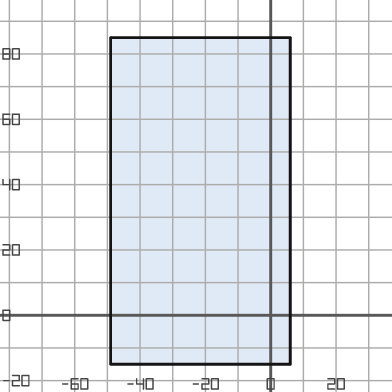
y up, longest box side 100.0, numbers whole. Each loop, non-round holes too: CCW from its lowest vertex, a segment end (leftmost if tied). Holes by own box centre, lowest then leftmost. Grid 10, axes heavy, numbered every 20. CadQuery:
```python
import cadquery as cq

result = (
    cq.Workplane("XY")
    .moveTo(-49.0, -15.0)
    .lineTo(6.0, -15.0)
    .lineTo(6.0, 85.0)
    .lineTo(-49.0, 85.0)
    .close()
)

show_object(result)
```